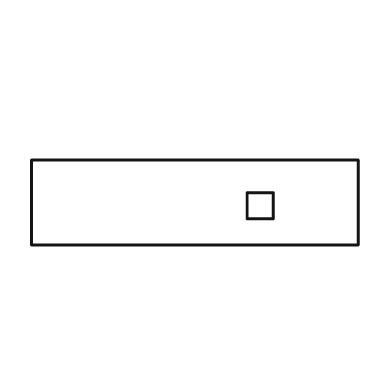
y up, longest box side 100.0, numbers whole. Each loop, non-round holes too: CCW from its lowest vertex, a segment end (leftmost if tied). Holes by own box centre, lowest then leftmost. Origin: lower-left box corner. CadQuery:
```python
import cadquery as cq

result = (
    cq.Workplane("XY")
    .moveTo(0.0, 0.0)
    .lineTo(100.0, 0.0)
    .lineTo(100.0, 26.0)
    .lineTo(0.0, 26.0)
    .close()
    .moveTo(66.0, 8.0)
    .lineTo(74.0, 8.0)
    .lineTo(74.0, 16.0)
    .lineTo(66.0, 16.0)
    .close()
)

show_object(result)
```